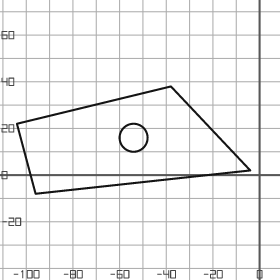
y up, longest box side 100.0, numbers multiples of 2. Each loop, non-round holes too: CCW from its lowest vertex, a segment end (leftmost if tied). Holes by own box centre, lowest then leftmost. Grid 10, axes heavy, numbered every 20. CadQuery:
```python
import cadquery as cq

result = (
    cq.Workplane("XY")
    .moveTo(-96.0, -8.0)
    .lineTo(-4.0, 2.0)
    .lineTo(-38.0, 38.0)
    .lineTo(-104.0, 22.0)
    .close()
    .moveTo(-54.0, 16.0)
    .circle(6.0)
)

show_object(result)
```